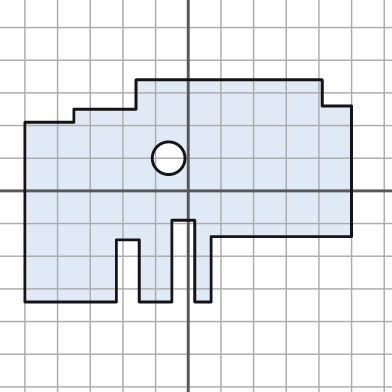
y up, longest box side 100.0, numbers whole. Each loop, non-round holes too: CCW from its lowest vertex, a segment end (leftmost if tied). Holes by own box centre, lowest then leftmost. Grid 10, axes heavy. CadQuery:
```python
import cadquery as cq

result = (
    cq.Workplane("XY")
    .moveTo(-50.0, -34.0)
    .lineTo(-22.0, -34.0)
    .lineTo(-22.0, -15.0)
    .lineTo(-15.0, -15.0)
    .lineTo(-15.0, -34.0)
    .lineTo(-5.0, -34.0)
    .lineTo(-5.0, -9.0)
    .lineTo(2.0, -9.0)
    .lineTo(2.0, -34.0)
    .lineTo(7.0, -34.0)
    .lineTo(7.0, -14.0)
    .lineTo(50.0, -14.0)
    .lineTo(50.0, 26.0)
    .lineTo(41.0, 26.0)
    .lineTo(41.0, 34.0)
    .lineTo(-16.0, 34.0)
    .lineTo(-16.0, 25.0)
    .lineTo(-35.0, 25.0)
    .lineTo(-35.0, 21.0)
    .lineTo(-50.0, 21.0)
    .close()
    .moveTo(-6.0, 10.0)
    .circle(5.0)
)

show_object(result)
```